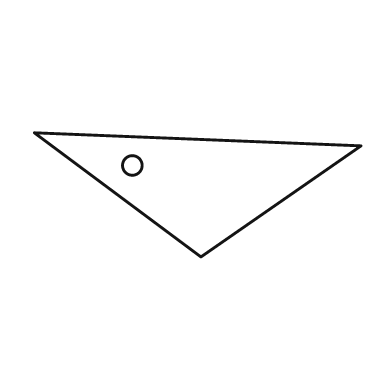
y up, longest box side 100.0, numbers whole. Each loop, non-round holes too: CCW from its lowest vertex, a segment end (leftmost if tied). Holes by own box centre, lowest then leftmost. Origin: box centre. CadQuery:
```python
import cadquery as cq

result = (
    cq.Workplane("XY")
    .moveTo(1.0, -19.0)
    .lineTo(50.0, 15.0)
    .lineTo(-50.0, 19.0)
    .close()
    .moveTo(-20.0, 9.0)
    .circle(3.0)
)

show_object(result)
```